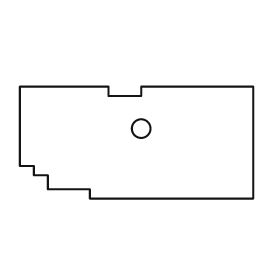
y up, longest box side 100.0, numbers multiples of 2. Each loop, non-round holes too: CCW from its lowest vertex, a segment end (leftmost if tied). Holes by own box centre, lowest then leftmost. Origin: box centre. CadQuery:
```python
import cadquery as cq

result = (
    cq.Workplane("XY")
    .moveTo(-20.0, -24.0)
    .lineTo(50.0, -24.0)
    .lineTo(50.0, 24.0)
    .lineTo(2.0, 24.0)
    .lineTo(2.0, 20.0)
    .lineTo(-12.0, 20.0)
    .lineTo(-12.0, 24.0)
    .lineTo(-50.0, 24.0)
    .lineTo(-50.0, -10.0)
    .lineTo(-44.0, -10.0)
    .lineTo(-44.0, -14.0)
    .lineTo(-38.0, -14.0)
    .lineTo(-38.0, -20.0)
    .lineTo(-20.0, -20.0)
    .close()
    .moveTo(2.0, 6.0)
    .circle(4.0)
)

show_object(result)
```